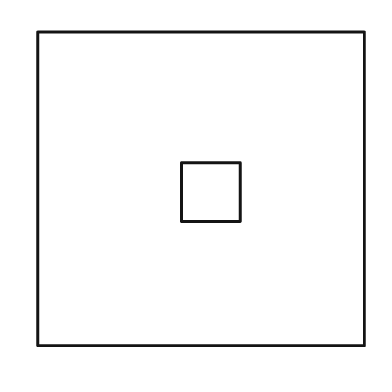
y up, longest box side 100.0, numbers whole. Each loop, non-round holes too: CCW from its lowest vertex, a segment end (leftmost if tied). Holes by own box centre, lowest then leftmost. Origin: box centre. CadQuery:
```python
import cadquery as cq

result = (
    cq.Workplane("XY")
    .moveTo(-50.0, -48.0)
    .lineTo(50.0, -48.0)
    .lineTo(50.0, 48.0)
    .lineTo(-50.0, 48.0)
    .close()
    .moveTo(-6.0, -10.0)
    .lineTo(12.0, -10.0)
    .lineTo(12.0, 8.0)
    .lineTo(-6.0, 8.0)
    .close()
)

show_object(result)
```